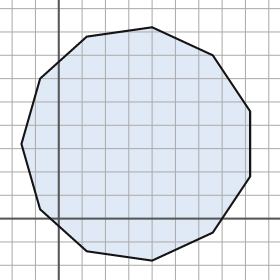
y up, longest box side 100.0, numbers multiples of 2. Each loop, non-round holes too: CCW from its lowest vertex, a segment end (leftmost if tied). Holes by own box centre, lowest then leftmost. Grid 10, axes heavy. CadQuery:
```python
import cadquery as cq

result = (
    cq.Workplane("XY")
    .moveTo(40.0, -18.0)
    .lineTo(66.0, -6.0)
    .lineTo(82.0, 18.0)
    .lineTo(82.0, 46.0)
    .lineTo(66.0, 70.0)
    .lineTo(40.0, 82.0)
    .lineTo(12.0, 78.0)
    .lineTo(-8.0, 60.0)
    .lineTo(-16.0, 32.0)
    .lineTo(-8.0, 4.0)
    .lineTo(12.0, -14.0)
    .close()
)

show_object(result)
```